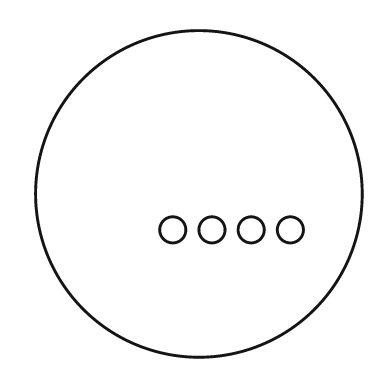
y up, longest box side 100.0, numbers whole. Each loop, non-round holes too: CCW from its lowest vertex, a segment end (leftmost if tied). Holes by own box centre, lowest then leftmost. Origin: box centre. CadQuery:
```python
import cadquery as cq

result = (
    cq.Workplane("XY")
    .moveTo(0.0, 0.0)
    .circle(50.0)
    .moveTo(-8.0, -11.0)
    .circle(4.0)
    .moveTo(4.0, -11.0)
    .circle(4.0)
    .moveTo(16.0, -11.0)
    .circle(4.0)
    .moveTo(28.0, -11.0)
    .circle(4.0)
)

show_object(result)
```